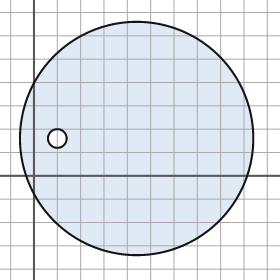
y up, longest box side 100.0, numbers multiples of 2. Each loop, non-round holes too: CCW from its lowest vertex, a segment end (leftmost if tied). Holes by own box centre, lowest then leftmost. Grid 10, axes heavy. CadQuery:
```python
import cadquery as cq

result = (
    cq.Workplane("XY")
    .moveTo(44.0, 16.0)
    .circle(50.0)
    .moveTo(10.0, 16.0)
    .circle(4.0)
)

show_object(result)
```